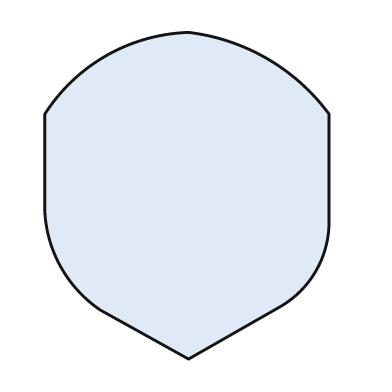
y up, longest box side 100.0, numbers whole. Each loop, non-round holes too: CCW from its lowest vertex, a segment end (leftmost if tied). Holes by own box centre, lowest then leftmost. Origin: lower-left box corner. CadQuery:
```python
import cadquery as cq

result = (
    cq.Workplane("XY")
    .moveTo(44.0, 0.0)
    .lineTo(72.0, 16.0)
    .threePointArc((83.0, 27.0), (87.0, 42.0))
    .lineTo(87.0, 75.0)
    .threePointArc((68.0, 92.0), (44.0, 100.0))
    .threePointArc((19.0, 93.0), (0.0, 75.0))
    .lineTo(0.0, 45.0)
    .threePointArc((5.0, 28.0), (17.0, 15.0))
    .close()
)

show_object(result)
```